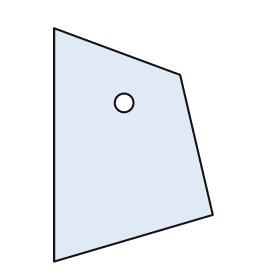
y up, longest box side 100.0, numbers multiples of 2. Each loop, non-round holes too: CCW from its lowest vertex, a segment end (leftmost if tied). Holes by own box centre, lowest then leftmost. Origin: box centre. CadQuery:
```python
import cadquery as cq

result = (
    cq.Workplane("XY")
    .moveTo(-34.0, -50.0)
    .lineTo(34.0, -30.0)
    .lineTo(20.0, 30.0)
    .lineTo(-34.0, 50.0)
    .close()
    .moveTo(-4.0, 18.0)
    .circle(4.0)
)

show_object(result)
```